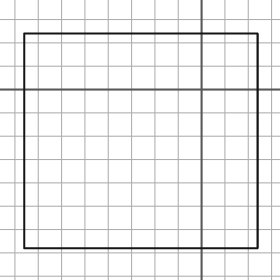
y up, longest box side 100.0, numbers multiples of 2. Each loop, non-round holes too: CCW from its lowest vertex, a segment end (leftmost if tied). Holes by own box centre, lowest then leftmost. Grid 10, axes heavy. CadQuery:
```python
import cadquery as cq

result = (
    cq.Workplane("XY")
    .moveTo(-76.0, -68.0)
    .lineTo(24.0, -68.0)
    .lineTo(24.0, 24.0)
    .lineTo(-76.0, 24.0)
    .close()
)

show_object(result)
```